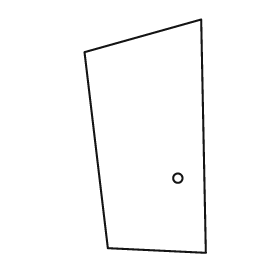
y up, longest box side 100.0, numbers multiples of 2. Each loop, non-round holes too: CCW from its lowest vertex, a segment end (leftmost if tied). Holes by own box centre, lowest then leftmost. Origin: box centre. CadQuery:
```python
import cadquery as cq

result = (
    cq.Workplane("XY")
    .moveTo(26.0, -50.0)
    .lineTo(24.0, 50.0)
    .lineTo(-26.0, 36.0)
    .lineTo(-16.0, -48.0)
    .close()
    .moveTo(14.0, -18.0)
    .circle(2.0)
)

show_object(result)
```